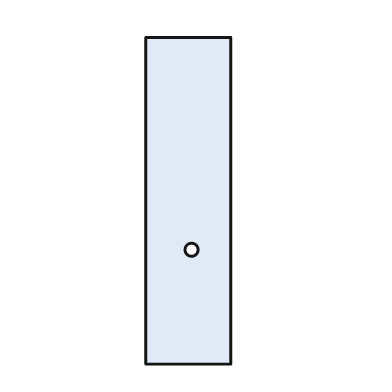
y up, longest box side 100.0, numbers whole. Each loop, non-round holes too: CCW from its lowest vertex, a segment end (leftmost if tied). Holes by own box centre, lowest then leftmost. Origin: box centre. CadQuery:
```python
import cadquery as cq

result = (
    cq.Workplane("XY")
    .moveTo(-13.0, -50.0)
    .lineTo(13.0, -50.0)
    .lineTo(13.0, 50.0)
    .lineTo(-13.0, 50.0)
    .close()
    .moveTo(1.0, -15.0)
    .circle(2.0)
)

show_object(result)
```